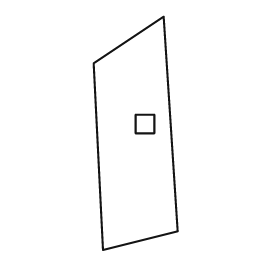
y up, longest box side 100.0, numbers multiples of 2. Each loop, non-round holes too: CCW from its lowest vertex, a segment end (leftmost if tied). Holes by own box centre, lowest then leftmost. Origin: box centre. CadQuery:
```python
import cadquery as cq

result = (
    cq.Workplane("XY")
    .moveTo(-14.0, -50.0)
    .lineTo(18.0, -42.0)
    .lineTo(12.0, 50.0)
    .lineTo(-18.0, 30.0)
    .close()
    .moveTo(0.0, 0.0)
    .lineTo(8.0, 0.0)
    .lineTo(8.0, 8.0)
    .lineTo(0.0, 8.0)
    .close()
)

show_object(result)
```